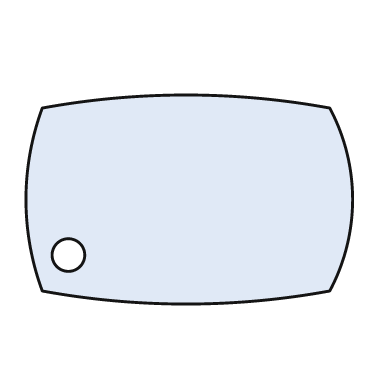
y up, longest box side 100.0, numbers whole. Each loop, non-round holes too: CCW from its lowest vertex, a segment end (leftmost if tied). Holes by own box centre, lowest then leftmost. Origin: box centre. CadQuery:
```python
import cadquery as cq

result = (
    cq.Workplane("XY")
    .moveTo(-45.0, -28.0)
    .threePointArc((-1.0, -32.0), (43.0, -28.0))
    .threePointArc((50.0, 0.0), (43.0, 28.0))
    .threePointArc((-1.0, 32.0), (-45.0, 28.0))
    .threePointArc((-50.0, 0.0), (-45.0, -28.0))
    .close()
    .moveTo(-37.0, -17.0)
    .circle(5.0)
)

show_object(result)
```